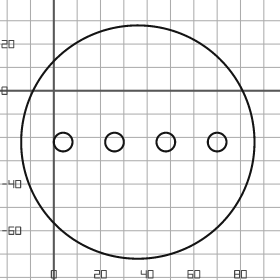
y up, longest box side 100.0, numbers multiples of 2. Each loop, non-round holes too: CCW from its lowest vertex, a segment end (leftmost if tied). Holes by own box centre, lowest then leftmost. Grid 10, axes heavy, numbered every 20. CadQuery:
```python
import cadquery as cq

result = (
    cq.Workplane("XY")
    .moveTo(36.0, -22.0)
    .circle(50.0)
    .moveTo(4.0, -22.0)
    .circle(4.0)
    .moveTo(26.0, -22.0)
    .circle(4.0)
    .moveTo(48.0, -22.0)
    .circle(4.0)
    .moveTo(70.0, -22.0)
    .circle(4.0)
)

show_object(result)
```